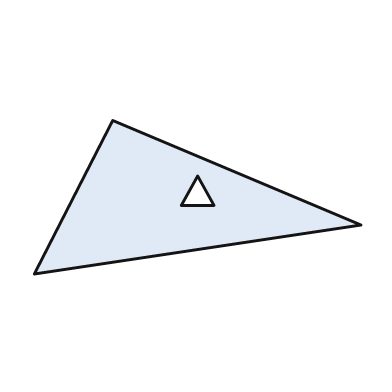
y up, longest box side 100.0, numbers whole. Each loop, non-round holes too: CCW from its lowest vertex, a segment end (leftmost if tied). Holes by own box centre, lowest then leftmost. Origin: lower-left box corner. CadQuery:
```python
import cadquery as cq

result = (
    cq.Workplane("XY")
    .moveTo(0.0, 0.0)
    .lineTo(100.0, 15.0)
    .lineTo(24.0, 47.0)
    .close()
    .moveTo(45.0, 21.0)
    .lineTo(55.0, 21.0)
    .lineTo(50.0, 30.0)
    .close()
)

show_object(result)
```